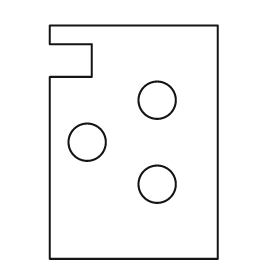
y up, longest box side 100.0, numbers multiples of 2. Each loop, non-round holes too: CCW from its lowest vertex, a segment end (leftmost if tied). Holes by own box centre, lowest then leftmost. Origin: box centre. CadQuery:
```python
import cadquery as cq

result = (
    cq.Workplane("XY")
    .moveTo(-36.0, -50.0)
    .lineTo(36.0, -50.0)
    .lineTo(36.0, 50.0)
    .lineTo(-36.0, 50.0)
    .lineTo(-36.0, 42.0)
    .lineTo(-18.0, 42.0)
    .lineTo(-18.0, 28.0)
    .lineTo(-36.0, 28.0)
    .close()
    .moveTo(10.0, -18.0)
    .circle(8.0)
    .moveTo(-20.0, 0.0)
    .circle(8.0)
    .moveTo(10.0, 18.0)
    .circle(8.0)
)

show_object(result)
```